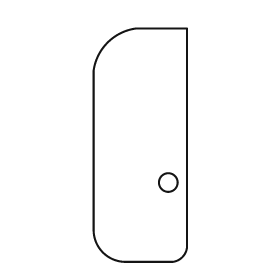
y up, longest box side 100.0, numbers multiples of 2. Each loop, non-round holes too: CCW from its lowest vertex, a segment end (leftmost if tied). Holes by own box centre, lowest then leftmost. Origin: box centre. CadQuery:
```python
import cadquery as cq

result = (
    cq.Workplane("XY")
    .moveTo(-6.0, -50.0)
    .lineTo(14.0, -50.0)
    .threePointArc((18.0, -48.0), (20.0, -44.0))
    .lineTo(20.0, 50.0)
    .lineTo(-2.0, 50.0)
    .threePointArc((-14.0, 44.0), (-20.0, 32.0))
    .lineTo(-20.0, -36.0)
    .threePointArc((-16.0, -46.0), (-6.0, -50.0))
    .close()
    .moveTo(12.0, -16.0)
    .circle(4.0)
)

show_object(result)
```